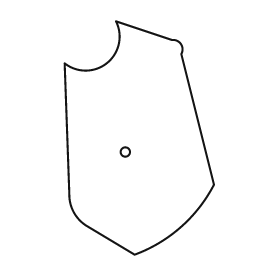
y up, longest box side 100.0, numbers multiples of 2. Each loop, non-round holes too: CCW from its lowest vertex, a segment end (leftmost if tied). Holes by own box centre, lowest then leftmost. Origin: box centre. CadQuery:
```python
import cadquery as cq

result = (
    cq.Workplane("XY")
    .moveTo(-2.0, -50.0)
    .threePointArc((18.0, -38.0), (32.0, -20.0))
    .lineTo(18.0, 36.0)
    .threePointArc((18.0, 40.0), (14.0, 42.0))
    .lineTo(-10.0, 50.0)
    .threePointArc((-14.0, 32.0), (-32.0, 32.0))
    .lineTo(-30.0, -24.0)
    .threePointArc((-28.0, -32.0), (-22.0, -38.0))
    .close()
    .moveTo(-6.0, -6.0)
    .circle(2.0)
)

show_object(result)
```